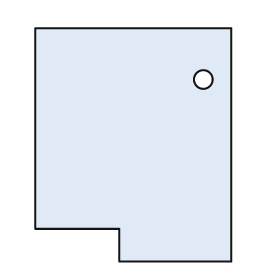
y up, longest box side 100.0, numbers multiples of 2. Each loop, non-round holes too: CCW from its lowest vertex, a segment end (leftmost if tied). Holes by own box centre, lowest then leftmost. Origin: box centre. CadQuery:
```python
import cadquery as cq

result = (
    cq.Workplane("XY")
    .moveTo(-6.0, -50.0)
    .lineTo(42.0, -50.0)
    .lineTo(42.0, 50.0)
    .lineTo(-42.0, 50.0)
    .lineTo(-42.0, -36.0)
    .lineTo(-6.0, -36.0)
    .close()
    .moveTo(30.0, 28.0)
    .circle(4.0)
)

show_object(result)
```